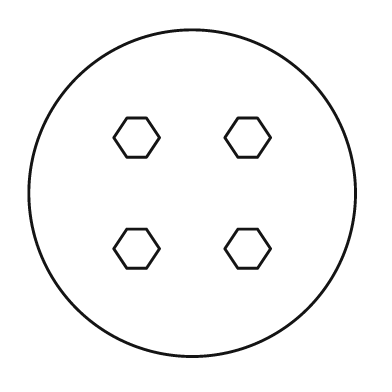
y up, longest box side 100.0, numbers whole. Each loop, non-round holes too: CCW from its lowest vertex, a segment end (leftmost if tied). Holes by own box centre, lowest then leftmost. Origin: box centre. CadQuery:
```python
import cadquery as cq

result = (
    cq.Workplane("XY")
    .moveTo(0.0, 0.0)
    .circle(50.0)
    .moveTo(-20.0, -23.0)
    .lineTo(-14.0, -23.0)
    .lineTo(-10.0, -17.0)
    .lineTo(-14.0, -11.0)
    .lineTo(-20.0, -11.0)
    .lineTo(-24.0, -17.0)
    .close()
    .moveTo(14.0, -23.0)
    .lineTo(20.0, -23.0)
    .lineTo(24.0, -17.0)
    .lineTo(20.0, -11.0)
    .lineTo(14.0, -11.0)
    .lineTo(10.0, -17.0)
    .close()
    .moveTo(-20.0, 11.0)
    .lineTo(-14.0, 11.0)
    .lineTo(-10.0, 17.0)
    .lineTo(-14.0, 23.0)
    .lineTo(-20.0, 23.0)
    .lineTo(-24.0, 17.0)
    .close()
    .moveTo(14.0, 11.0)
    .lineTo(20.0, 11.0)
    .lineTo(24.0, 17.0)
    .lineTo(20.0, 23.0)
    .lineTo(14.0, 23.0)
    .lineTo(10.0, 17.0)
    .close()
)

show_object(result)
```